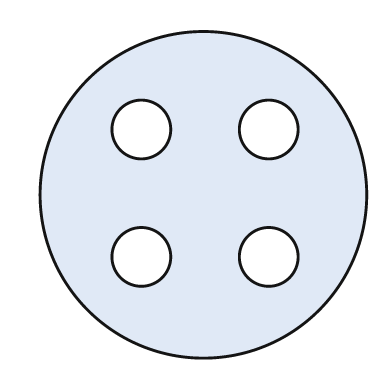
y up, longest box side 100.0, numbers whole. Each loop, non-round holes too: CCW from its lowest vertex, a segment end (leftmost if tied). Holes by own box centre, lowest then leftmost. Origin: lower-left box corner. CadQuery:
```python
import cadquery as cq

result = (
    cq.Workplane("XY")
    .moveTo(50.0, 50.0)
    .circle(50.0)
    .moveTo(31.0, 31.0)
    .circle(9.0)
    .moveTo(70.0, 31.0)
    .circle(9.0)
    .moveTo(31.0, 70.0)
    .circle(9.0)
    .moveTo(70.0, 70.0)
    .circle(9.0)
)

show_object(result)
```